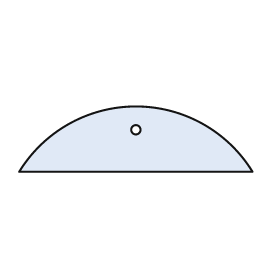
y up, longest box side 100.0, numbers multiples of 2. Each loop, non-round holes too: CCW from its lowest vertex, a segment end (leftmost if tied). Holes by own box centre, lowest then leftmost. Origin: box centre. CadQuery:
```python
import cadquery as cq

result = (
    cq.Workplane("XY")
    .moveTo(-50.0, -14.0)
    .lineTo(50.0, -14.0)
    .threePointArc((0.0, 14.0), (-50.0, -14.0))
    .close()
    .moveTo(0.0, 4.0)
    .circle(2.0)
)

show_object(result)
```